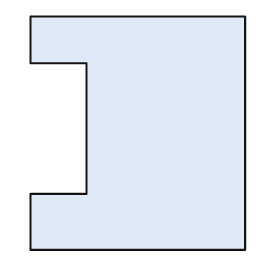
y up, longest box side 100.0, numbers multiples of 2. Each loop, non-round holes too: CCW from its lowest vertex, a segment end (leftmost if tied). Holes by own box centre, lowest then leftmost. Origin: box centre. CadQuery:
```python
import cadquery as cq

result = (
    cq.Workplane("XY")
    .moveTo(-46.0, -50.0)
    .lineTo(46.0, -50.0)
    .lineTo(46.0, 50.0)
    .lineTo(-46.0, 50.0)
    .lineTo(-46.0, 30.0)
    .lineTo(-22.0, 30.0)
    .lineTo(-22.0, -26.0)
    .lineTo(-46.0, -26.0)
    .close()
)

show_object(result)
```